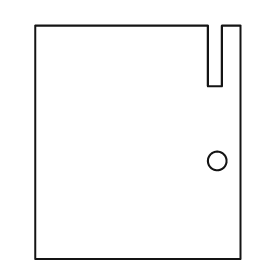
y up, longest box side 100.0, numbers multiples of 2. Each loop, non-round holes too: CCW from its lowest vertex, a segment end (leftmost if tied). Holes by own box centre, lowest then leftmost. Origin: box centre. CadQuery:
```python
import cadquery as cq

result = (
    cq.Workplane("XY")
    .moveTo(-44.0, -50.0)
    .lineTo(44.0, -50.0)
    .lineTo(44.0, 50.0)
    .lineTo(36.0, 50.0)
    .lineTo(36.0, 24.0)
    .lineTo(30.0, 24.0)
    .lineTo(30.0, 50.0)
    .lineTo(-44.0, 50.0)
    .close()
    .moveTo(34.0, -8.0)
    .circle(4.0)
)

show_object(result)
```